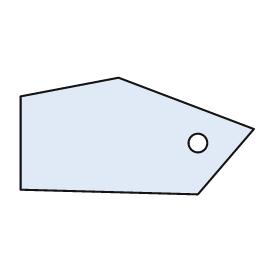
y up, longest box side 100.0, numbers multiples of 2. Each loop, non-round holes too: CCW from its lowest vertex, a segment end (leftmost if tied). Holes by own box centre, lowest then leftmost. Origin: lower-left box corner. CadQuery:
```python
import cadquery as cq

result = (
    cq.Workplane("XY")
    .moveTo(76.0, 0.0)
    .lineTo(100.0, 28.0)
    .lineTo(42.0, 50.0)
    .lineTo(0.0, 42.0)
    .lineTo(0.0, 2.0)
    .close()
    .moveTo(76.0, 22.0)
    .circle(4.0)
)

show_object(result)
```